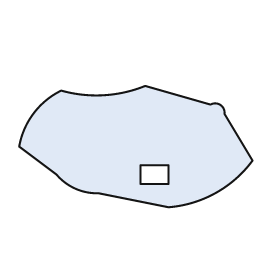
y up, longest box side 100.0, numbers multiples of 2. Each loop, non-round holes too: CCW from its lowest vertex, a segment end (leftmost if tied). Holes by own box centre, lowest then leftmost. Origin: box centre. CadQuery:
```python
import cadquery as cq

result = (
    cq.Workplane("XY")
    .moveTo(14.0, -26.0)
    .threePointArc((34.0, -20.0), (50.0, -6.0))
    .lineTo(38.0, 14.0)
    .threePointArc((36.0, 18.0), (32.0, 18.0))
    .lineTo(4.0, 26.0)
    .threePointArc((-14.0, 22.0), (-32.0, 24.0))
    .threePointArc((-44.0, 14.0), (-50.0, 0.0))
    .lineTo(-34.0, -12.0)
    .threePointArc((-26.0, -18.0), (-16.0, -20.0))
    .close()
    .moveTo(2.0, -16.0)
    .lineTo(14.0, -16.0)
    .lineTo(14.0, -8.0)
    .lineTo(2.0, -8.0)
    .close()
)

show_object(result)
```